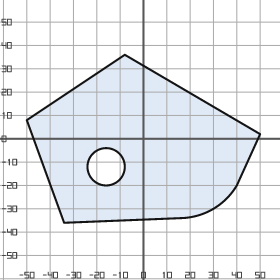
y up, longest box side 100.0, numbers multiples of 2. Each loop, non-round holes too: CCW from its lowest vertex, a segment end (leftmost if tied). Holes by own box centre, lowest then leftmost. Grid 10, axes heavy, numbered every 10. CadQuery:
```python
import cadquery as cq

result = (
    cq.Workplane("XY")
    .moveTo(-34.0, -36.0)
    .lineTo(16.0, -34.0)
    .threePointArc((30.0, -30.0), (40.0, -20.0))
    .lineTo(50.0, 2.0)
    .lineTo(-8.0, 36.0)
    .lineTo(-50.0, 8.0)
    .close()
    .moveTo(-16.0, -12.0)
    .circle(8.0)
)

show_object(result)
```